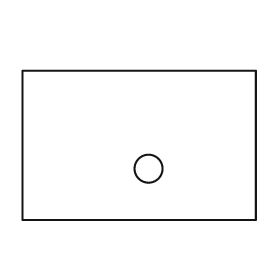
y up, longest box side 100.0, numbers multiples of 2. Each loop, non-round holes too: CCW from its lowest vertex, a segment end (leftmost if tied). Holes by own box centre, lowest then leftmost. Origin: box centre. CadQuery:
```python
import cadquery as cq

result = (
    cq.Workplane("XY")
    .moveTo(-50.0, -32.0)
    .lineTo(50.0, -32.0)
    .lineTo(50.0, 32.0)
    .lineTo(-50.0, 32.0)
    .close()
    .moveTo(4.0, -10.0)
    .circle(6.0)
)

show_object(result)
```